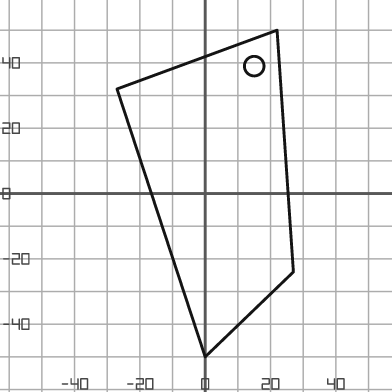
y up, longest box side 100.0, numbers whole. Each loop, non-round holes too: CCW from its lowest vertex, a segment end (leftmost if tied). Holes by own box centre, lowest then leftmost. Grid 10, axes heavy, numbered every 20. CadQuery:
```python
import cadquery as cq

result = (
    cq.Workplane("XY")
    .moveTo(0.0, -50.0)
    .lineTo(27.0, -24.0)
    .lineTo(22.0, 50.0)
    .lineTo(-27.0, 32.0)
    .close()
    .moveTo(15.0, 39.0)
    .circle(3.0)
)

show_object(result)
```